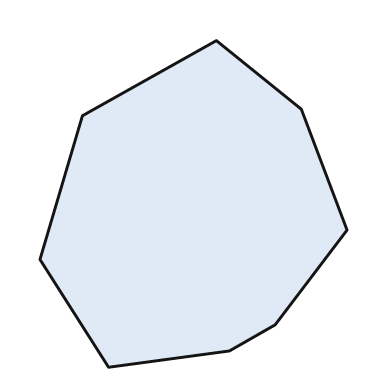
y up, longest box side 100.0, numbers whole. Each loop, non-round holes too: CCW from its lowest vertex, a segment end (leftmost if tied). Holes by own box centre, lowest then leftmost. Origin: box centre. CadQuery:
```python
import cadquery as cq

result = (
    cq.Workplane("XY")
    .moveTo(-26.0, -50.0)
    .lineTo(11.0, -45.0)
    .lineTo(25.0, -37.0)
    .lineTo(47.0, -8.0)
    .lineTo(33.0, 29.0)
    .lineTo(7.0, 50.0)
    .lineTo(-34.0, 27.0)
    .lineTo(-47.0, -17.0)
    .close()
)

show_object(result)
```